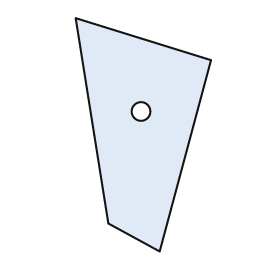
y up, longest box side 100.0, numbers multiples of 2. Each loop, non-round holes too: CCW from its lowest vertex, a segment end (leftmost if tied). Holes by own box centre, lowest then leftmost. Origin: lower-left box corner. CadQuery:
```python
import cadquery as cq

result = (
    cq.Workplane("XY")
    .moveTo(36.0, 0.0)
    .lineTo(58.0, 82.0)
    .lineTo(0.0, 100.0)
    .lineTo(14.0, 12.0)
    .close()
    .moveTo(28.0, 60.0)
    .circle(4.0)
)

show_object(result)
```